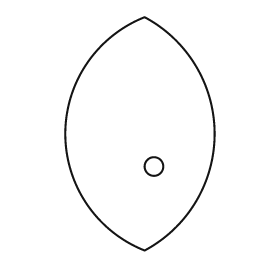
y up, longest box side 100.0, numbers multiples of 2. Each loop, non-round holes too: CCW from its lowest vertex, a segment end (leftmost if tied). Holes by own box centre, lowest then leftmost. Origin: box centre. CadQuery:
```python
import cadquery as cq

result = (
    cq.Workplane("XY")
    .moveTo(2.0, -50.0)
    .threePointArc((32.0, 0.0), (2.0, 50.0))
    .threePointArc((-32.0, 0.0), (2.0, -50.0))
    .close()
    .moveTo(6.0, -14.0)
    .circle(4.0)
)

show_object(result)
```